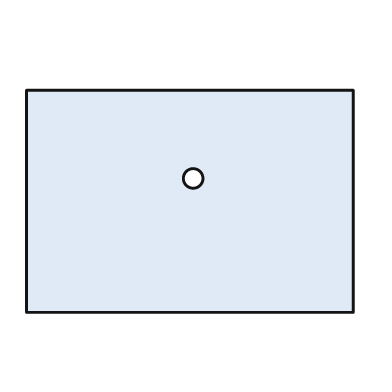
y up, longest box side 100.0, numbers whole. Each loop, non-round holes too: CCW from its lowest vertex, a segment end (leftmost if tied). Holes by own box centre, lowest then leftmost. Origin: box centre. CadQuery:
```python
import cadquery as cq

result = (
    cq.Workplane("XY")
    .moveTo(-50.0, -34.0)
    .lineTo(50.0, -34.0)
    .lineTo(50.0, 34.0)
    .lineTo(-50.0, 34.0)
    .close()
    .moveTo(1.0, 7.0)
    .circle(3.0)
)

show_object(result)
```